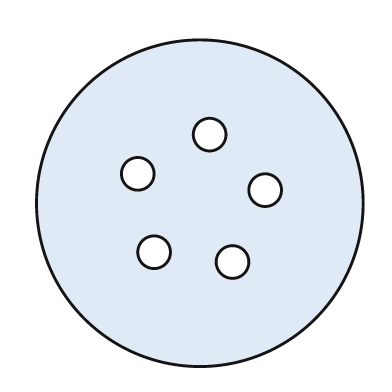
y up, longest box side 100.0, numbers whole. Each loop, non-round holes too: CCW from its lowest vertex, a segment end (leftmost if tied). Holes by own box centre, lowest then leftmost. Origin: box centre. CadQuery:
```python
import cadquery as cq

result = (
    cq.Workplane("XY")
    .moveTo(0.0, 0.0)
    .circle(50.0)
    .moveTo(10.0, -18.0)
    .circle(5.0)
    .moveTo(-14.0, -15.0)
    .circle(5.0)
    .moveTo(20.0, 4.0)
    .circle(5.0)
    .moveTo(-19.0, 9.0)
    .circle(5.0)
    .moveTo(3.0, 21.0)
    .circle(5.0)
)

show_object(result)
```